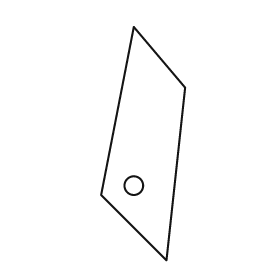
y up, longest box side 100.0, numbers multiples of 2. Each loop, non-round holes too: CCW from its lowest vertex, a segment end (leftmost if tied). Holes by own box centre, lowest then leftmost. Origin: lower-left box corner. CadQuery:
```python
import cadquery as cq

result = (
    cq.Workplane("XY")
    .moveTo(28.0, 0.0)
    .lineTo(36.0, 74.0)
    .lineTo(14.0, 100.0)
    .lineTo(0.0, 28.0)
    .close()
    .moveTo(14.0, 32.0)
    .circle(4.0)
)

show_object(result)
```